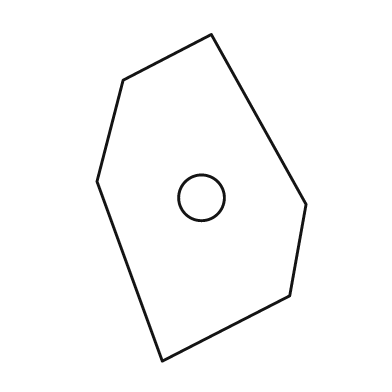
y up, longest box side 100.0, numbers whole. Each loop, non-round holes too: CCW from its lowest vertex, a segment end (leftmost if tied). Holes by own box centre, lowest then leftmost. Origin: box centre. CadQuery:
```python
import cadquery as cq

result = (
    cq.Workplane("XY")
    .moveTo(-12.0, -50.0)
    .lineTo(27.0, -30.0)
    .lineTo(32.0, -2.0)
    .lineTo(3.0, 50.0)
    .lineTo(-24.0, 36.0)
    .lineTo(-32.0, 5.0)
    .close()
    .moveTo(0.0, 0.0)
    .circle(7.0)
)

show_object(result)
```